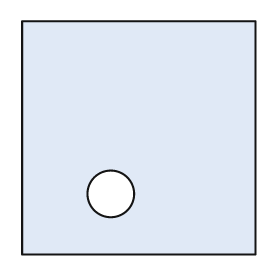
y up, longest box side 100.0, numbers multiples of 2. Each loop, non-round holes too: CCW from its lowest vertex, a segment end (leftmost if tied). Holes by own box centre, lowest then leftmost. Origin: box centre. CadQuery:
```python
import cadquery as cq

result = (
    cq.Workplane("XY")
    .moveTo(-50.0, -50.0)
    .lineTo(50.0, -50.0)
    .lineTo(50.0, 50.0)
    .lineTo(-50.0, 50.0)
    .close()
    .moveTo(-12.0, -24.0)
    .circle(10.0)
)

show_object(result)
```